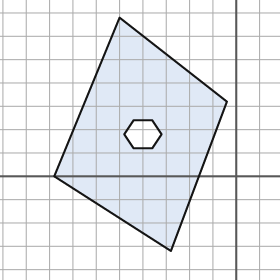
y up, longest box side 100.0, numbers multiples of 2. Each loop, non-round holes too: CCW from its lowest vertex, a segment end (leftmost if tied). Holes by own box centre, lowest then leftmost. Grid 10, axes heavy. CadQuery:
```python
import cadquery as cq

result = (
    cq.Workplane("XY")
    .moveTo(-28.0, -32.0)
    .lineTo(-4.0, 32.0)
    .lineTo(-50.0, 68.0)
    .lineTo(-78.0, 0.0)
    .close()
    .moveTo(-44.0, 12.0)
    .lineTo(-36.0, 12.0)
    .lineTo(-32.0, 18.0)
    .lineTo(-36.0, 24.0)
    .lineTo(-44.0, 24.0)
    .lineTo(-48.0, 18.0)
    .close()
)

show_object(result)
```